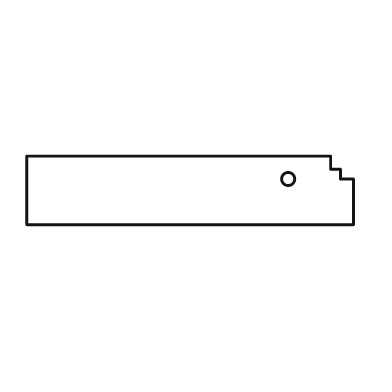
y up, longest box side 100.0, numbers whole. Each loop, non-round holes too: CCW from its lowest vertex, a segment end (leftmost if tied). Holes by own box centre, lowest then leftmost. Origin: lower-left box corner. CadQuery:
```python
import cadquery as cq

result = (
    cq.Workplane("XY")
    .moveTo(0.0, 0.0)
    .lineTo(100.0, 0.0)
    .lineTo(100.0, 14.0)
    .lineTo(96.0, 14.0)
    .lineTo(96.0, 17.0)
    .lineTo(93.0, 17.0)
    .lineTo(93.0, 21.0)
    .lineTo(0.0, 21.0)
    .close()
    .moveTo(80.0, 14.0)
    .circle(2.0)
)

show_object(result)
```